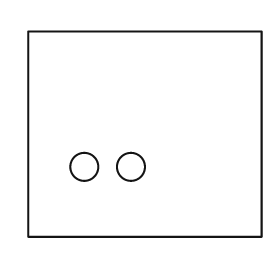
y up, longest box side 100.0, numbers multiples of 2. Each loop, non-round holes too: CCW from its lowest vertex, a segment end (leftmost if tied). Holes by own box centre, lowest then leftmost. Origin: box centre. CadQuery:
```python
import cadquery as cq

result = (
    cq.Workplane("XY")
    .moveTo(-50.0, -44.0)
    .lineTo(50.0, -44.0)
    .lineTo(50.0, 44.0)
    .lineTo(-50.0, 44.0)
    .close()
    .moveTo(-26.0, -14.0)
    .circle(6.0)
    .moveTo(-6.0, -14.0)
    .circle(6.0)
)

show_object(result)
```